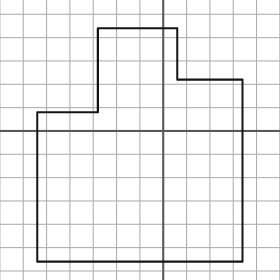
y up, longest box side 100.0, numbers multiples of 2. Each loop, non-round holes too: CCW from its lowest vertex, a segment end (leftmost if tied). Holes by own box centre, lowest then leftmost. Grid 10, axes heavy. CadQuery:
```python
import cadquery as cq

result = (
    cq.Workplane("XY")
    .moveTo(-54.0, -56.0)
    .lineTo(34.0, -56.0)
    .lineTo(34.0, 22.0)
    .lineTo(6.0, 22.0)
    .lineTo(6.0, 44.0)
    .lineTo(-28.0, 44.0)
    .lineTo(-28.0, 8.0)
    .lineTo(-54.0, 8.0)
    .close()
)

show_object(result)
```